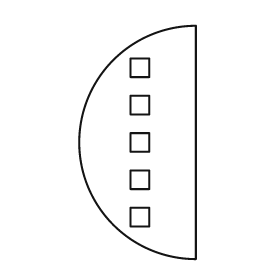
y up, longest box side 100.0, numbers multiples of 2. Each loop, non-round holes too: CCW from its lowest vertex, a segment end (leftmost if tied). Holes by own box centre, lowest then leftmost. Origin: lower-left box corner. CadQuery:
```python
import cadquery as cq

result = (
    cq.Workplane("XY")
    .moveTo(50.0, 0.0)
    .lineTo(50.0, 100.0)
    .threePointArc((0.0, 50.0), (50.0, 0.0))
    .close()
    .moveTo(22.0, 14.0)
    .lineTo(30.0, 14.0)
    .lineTo(30.0, 22.0)
    .lineTo(22.0, 22.0)
    .close()
    .moveTo(22.0, 30.0)
    .lineTo(30.0, 30.0)
    .lineTo(30.0, 38.0)
    .lineTo(22.0, 38.0)
    .close()
    .moveTo(22.0, 46.0)
    .lineTo(30.0, 46.0)
    .lineTo(30.0, 54.0)
    .lineTo(22.0, 54.0)
    .close()
    .moveTo(22.0, 62.0)
    .lineTo(30.0, 62.0)
    .lineTo(30.0, 70.0)
    .lineTo(22.0, 70.0)
    .close()
    .moveTo(22.0, 78.0)
    .lineTo(30.0, 78.0)
    .lineTo(30.0, 86.0)
    .lineTo(22.0, 86.0)
    .close()
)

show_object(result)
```